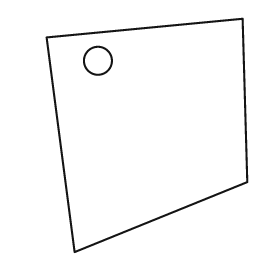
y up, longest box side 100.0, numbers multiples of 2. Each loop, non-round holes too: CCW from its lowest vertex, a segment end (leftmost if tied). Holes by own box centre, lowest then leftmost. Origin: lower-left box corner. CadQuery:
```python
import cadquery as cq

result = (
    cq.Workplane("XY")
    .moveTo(12.0, 0.0)
    .lineTo(86.0, 30.0)
    .lineTo(84.0, 100.0)
    .lineTo(0.0, 92.0)
    .close()
    .moveTo(22.0, 82.0)
    .circle(6.0)
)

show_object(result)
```